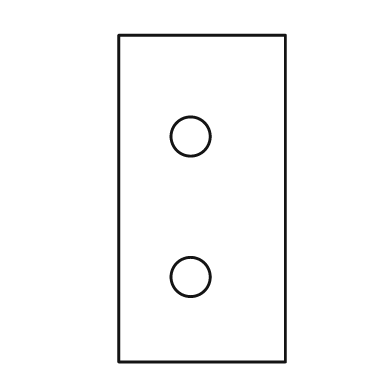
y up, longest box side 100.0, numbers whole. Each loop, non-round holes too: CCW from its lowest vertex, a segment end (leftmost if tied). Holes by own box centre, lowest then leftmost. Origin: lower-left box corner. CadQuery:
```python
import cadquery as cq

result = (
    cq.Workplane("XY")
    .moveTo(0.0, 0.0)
    .lineTo(51.0, 0.0)
    .lineTo(51.0, 100.0)
    .lineTo(0.0, 100.0)
    .close()
    .moveTo(22.0, 26.0)
    .circle(6.0)
    .moveTo(22.0, 69.0)
    .circle(6.0)
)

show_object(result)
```